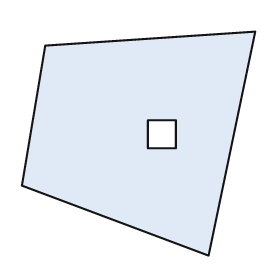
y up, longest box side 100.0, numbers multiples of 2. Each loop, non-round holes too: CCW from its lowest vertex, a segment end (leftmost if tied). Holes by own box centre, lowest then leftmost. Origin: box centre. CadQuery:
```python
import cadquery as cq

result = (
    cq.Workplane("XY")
    .moveTo(30.0, -48.0)
    .lineTo(50.0, 48.0)
    .lineTo(-40.0, 42.0)
    .lineTo(-50.0, -18.0)
    .close()
    .moveTo(4.0, -2.0)
    .lineTo(16.0, -2.0)
    .lineTo(16.0, 10.0)
    .lineTo(4.0, 10.0)
    .close()
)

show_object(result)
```